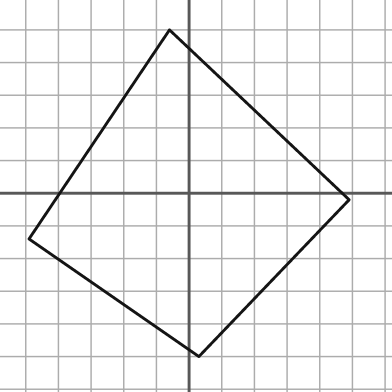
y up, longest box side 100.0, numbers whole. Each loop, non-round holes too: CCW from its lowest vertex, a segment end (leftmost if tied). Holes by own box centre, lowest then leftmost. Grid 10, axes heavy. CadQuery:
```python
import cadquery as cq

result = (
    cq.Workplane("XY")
    .moveTo(3.0, -50.0)
    .lineTo(49.0, -2.0)
    .lineTo(-6.0, 50.0)
    .lineTo(-49.0, -14.0)
    .close()
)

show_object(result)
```